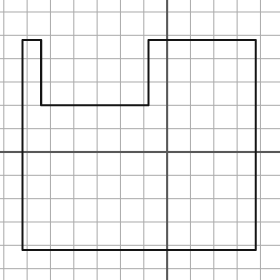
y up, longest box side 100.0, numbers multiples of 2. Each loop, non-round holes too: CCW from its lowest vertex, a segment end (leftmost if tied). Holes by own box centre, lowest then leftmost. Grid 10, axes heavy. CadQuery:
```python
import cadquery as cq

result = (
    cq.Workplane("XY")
    .moveTo(-62.0, -42.0)
    .lineTo(38.0, -42.0)
    .lineTo(38.0, 48.0)
    .lineTo(-8.0, 48.0)
    .lineTo(-8.0, 20.0)
    .lineTo(-54.0, 20.0)
    .lineTo(-54.0, 48.0)
    .lineTo(-62.0, 48.0)
    .close()
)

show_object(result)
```